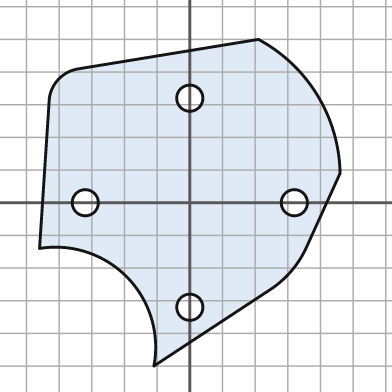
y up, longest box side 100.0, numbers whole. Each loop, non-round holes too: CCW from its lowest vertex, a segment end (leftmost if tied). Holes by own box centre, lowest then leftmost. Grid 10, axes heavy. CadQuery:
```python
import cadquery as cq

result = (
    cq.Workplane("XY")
    .moveTo(-11.0, -50.0)
    .lineTo(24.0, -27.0)
    .threePointArc((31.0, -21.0), (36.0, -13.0))
    .lineTo(46.0, 9.0)
    .threePointArc((39.0, 33.0), (21.0, 50.0))
    .lineTo(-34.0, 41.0)
    .threePointArc((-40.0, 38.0), (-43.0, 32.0))
    .lineTo(-46.0, -14.0)
    .threePointArc((-19.0, -23.0), (-11.0, -50.0))
    .close()
    .moveTo(0.0, -32.0)
    .circle(4.0)
    .moveTo(-32.0, 0.0)
    .circle(4.0)
    .moveTo(32.0, 0.0)
    .circle(4.0)
    .moveTo(0.0, 32.0)
    .circle(4.0)
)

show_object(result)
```